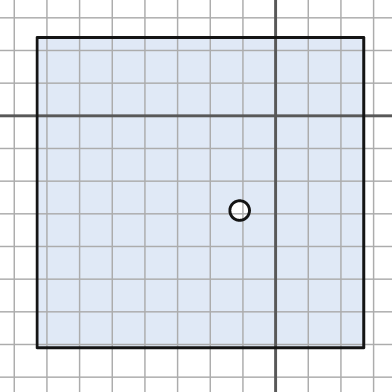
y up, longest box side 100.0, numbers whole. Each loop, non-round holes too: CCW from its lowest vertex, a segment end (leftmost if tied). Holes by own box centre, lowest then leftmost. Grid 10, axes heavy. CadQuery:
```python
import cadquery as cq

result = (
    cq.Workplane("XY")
    .moveTo(-73.0, -71.0)
    .lineTo(27.0, -71.0)
    .lineTo(27.0, 24.0)
    .lineTo(-73.0, 24.0)
    .close()
    .moveTo(-11.0, -29.0)
    .circle(3.0)
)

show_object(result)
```